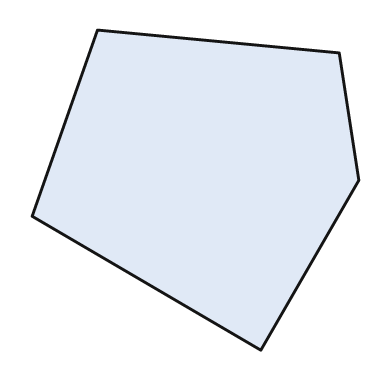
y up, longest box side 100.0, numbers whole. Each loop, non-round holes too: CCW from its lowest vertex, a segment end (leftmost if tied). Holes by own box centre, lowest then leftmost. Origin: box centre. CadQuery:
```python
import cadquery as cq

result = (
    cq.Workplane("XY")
    .moveTo(20.0, -49.0)
    .lineTo(50.0, 3.0)
    .lineTo(44.0, 42.0)
    .lineTo(-30.0, 49.0)
    .lineTo(-50.0, -8.0)
    .close()
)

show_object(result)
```